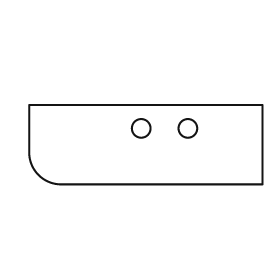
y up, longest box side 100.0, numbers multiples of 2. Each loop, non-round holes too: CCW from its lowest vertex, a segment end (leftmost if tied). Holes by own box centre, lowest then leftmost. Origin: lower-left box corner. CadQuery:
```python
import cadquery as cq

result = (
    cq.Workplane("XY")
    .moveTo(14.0, 0.0)
    .lineTo(100.0, 0.0)
    .lineTo(100.0, 34.0)
    .lineTo(0.0, 34.0)
    .lineTo(0.0, 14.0)
    .threePointArc((4.0, 4.0), (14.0, 0.0))
    .close()
    .moveTo(48.0, 24.0)
    .circle(4.0)
    .moveTo(68.0, 24.0)
    .circle(4.0)
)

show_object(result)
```